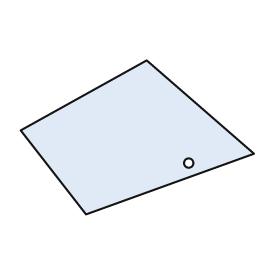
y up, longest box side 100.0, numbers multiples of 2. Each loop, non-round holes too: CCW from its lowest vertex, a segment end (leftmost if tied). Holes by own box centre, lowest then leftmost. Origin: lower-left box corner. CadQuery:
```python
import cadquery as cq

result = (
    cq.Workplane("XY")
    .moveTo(28.0, 0.0)
    .lineTo(100.0, 26.0)
    .lineTo(54.0, 66.0)
    .lineTo(0.0, 36.0)
    .close()
    .moveTo(72.0, 22.0)
    .circle(2.0)
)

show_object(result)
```